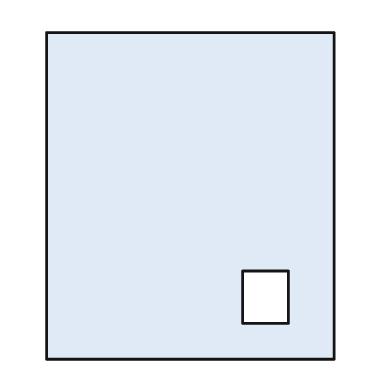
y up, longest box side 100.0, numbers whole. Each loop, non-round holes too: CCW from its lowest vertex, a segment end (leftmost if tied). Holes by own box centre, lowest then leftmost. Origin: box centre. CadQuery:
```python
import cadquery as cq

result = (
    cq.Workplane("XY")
    .moveTo(-44.0, -50.0)
    .lineTo(44.0, -50.0)
    .lineTo(44.0, 50.0)
    .lineTo(-44.0, 50.0)
    .close()
    .moveTo(16.0, -39.0)
    .lineTo(30.0, -39.0)
    .lineTo(30.0, -23.0)
    .lineTo(16.0, -23.0)
    .close()
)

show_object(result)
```